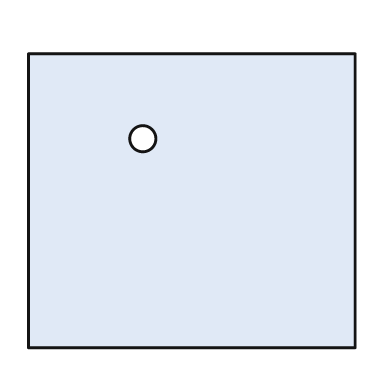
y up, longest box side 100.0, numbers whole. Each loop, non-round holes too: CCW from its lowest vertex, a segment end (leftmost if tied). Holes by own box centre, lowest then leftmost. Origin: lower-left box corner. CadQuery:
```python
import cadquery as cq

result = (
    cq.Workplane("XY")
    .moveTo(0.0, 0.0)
    .lineTo(100.0, 0.0)
    .lineTo(100.0, 90.0)
    .lineTo(0.0, 90.0)
    .close()
    .moveTo(35.0, 64.0)
    .circle(4.0)
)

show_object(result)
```